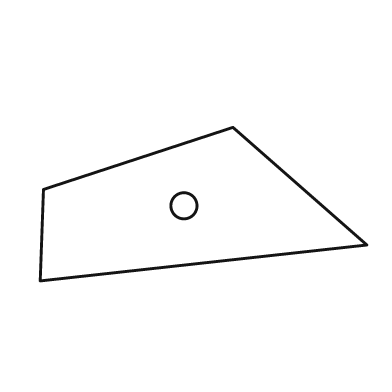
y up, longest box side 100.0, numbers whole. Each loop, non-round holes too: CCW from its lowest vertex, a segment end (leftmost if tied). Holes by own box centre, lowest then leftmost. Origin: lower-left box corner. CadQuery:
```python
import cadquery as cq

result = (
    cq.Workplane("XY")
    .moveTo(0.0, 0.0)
    .lineTo(100.0, 11.0)
    .lineTo(59.0, 47.0)
    .lineTo(1.0, 28.0)
    .close()
    .moveTo(44.0, 23.0)
    .circle(4.0)
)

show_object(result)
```